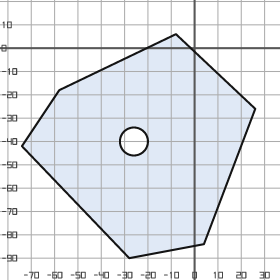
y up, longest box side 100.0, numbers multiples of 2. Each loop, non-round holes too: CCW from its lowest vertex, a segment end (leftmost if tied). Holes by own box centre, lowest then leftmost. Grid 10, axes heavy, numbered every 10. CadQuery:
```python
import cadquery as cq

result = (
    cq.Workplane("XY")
    .moveTo(-28.0, -90.0)
    .lineTo(4.0, -84.0)
    .lineTo(26.0, -26.0)
    .lineTo(-8.0, 6.0)
    .lineTo(-58.0, -18.0)
    .lineTo(-74.0, -42.0)
    .close()
    .moveTo(-26.0, -40.0)
    .circle(6.0)
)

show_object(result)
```